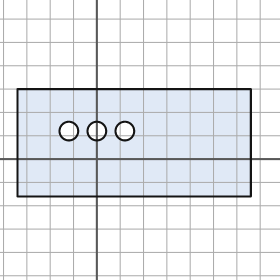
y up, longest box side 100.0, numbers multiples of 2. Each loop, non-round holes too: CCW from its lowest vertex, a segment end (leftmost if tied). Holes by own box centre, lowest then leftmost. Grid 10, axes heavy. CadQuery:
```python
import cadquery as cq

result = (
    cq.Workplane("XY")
    .moveTo(-34.0, -16.0)
    .lineTo(66.0, -16.0)
    .lineTo(66.0, 30.0)
    .lineTo(-34.0, 30.0)
    .close()
    .moveTo(-12.0, 12.0)
    .circle(4.0)
    .moveTo(0.0, 12.0)
    .circle(4.0)
    .moveTo(12.0, 12.0)
    .circle(4.0)
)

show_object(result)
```